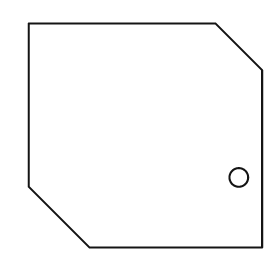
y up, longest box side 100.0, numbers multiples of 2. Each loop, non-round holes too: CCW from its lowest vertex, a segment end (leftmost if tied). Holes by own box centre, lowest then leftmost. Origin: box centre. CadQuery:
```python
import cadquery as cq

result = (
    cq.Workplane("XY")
    .moveTo(-24.0, -48.0)
    .lineTo(50.0, -48.0)
    .lineTo(50.0, 28.0)
    .lineTo(30.0, 48.0)
    .lineTo(-50.0, 48.0)
    .lineTo(-50.0, -22.0)
    .close()
    .moveTo(40.0, -18.0)
    .circle(4.0)
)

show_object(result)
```